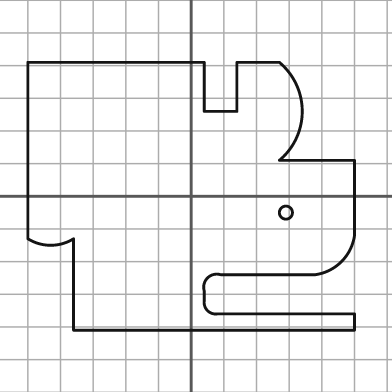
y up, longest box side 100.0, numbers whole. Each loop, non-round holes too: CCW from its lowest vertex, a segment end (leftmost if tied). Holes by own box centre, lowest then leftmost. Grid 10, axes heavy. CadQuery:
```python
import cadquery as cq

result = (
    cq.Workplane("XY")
    .moveTo(-36.0, -41.0)
    .lineTo(50.0, -41.0)
    .lineTo(50.0, -36.0)
    .lineTo(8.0, -36.0)
    .threePointArc((5.0, -35.0), (4.0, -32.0))
    .lineTo(4.0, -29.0)
    .threePointArc((5.0, -25.0), (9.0, -24.0))
    .lineTo(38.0, -24.0)
    .threePointArc((46.0, -20.0), (50.0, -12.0))
    .lineTo(50.0, 11.0)
    .lineTo(27.0, 11.0)
    .threePointArc((34.0, 26.0), (27.0, 41.0))
    .lineTo(14.0, 41.0)
    .lineTo(14.0, 26.0)
    .lineTo(4.0, 26.0)
    .lineTo(4.0, 41.0)
    .lineTo(-50.0, 41.0)
    .lineTo(-50.0, -13.0)
    .threePointArc((-43.0, -15.0), (-36.0, -13.0))
    .close()
    .moveTo(29.0, -5.0)
    .circle(2.0)
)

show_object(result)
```